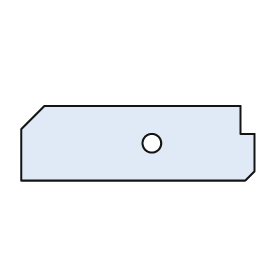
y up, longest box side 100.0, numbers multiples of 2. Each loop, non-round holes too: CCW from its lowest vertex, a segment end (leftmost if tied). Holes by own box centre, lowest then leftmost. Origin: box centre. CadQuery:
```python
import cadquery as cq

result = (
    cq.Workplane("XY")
    .moveTo(-50.0, -16.0)
    .lineTo(46.0, -16.0)
    .lineTo(50.0, -12.0)
    .lineTo(50.0, 4.0)
    .lineTo(44.0, 4.0)
    .lineTo(44.0, 16.0)
    .lineTo(-40.0, 16.0)
    .lineTo(-50.0, 6.0)
    .close()
    .moveTo(6.0, 0.0)
    .circle(4.0)
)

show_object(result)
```